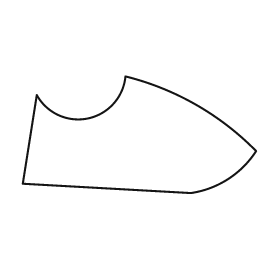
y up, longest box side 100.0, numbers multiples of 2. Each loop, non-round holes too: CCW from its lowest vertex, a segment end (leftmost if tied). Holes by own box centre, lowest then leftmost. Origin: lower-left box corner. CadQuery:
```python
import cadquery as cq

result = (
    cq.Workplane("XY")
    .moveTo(72.0, 0.0)
    .threePointArc((88.0, 6.0), (100.0, 18.0))
    .threePointArc((74.0, 38.0), (44.0, 50.0))
    .threePointArc((28.0, 32.0), (6.0, 42.0))
    .lineTo(0.0, 4.0)
    .close()
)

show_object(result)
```